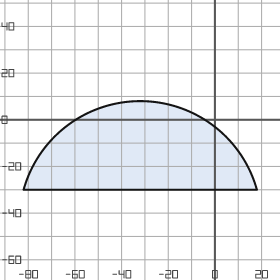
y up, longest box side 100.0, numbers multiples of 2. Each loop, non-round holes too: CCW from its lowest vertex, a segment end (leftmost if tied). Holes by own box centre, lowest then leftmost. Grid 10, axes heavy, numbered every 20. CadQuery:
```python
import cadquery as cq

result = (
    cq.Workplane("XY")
    .moveTo(-82.0, -30.0)
    .lineTo(18.0, -30.0)
    .threePointArc((-32.0, 8.0), (-82.0, -30.0))
    .close()
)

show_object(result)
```